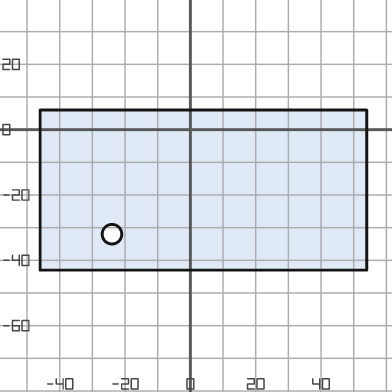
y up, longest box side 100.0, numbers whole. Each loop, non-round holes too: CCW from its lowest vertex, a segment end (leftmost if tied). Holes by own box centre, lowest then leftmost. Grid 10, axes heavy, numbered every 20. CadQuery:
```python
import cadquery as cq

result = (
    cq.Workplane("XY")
    .moveTo(-46.0, -43.0)
    .lineTo(54.0, -43.0)
    .lineTo(54.0, 6.0)
    .lineTo(-46.0, 6.0)
    .close()
    .moveTo(-24.0, -32.0)
    .circle(3.0)
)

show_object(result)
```